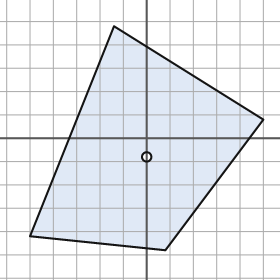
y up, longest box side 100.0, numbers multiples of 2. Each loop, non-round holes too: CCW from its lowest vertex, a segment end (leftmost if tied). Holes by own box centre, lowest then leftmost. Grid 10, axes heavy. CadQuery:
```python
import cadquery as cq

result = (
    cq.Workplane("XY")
    .moveTo(8.0, -48.0)
    .lineTo(50.0, 8.0)
    .lineTo(-14.0, 48.0)
    .lineTo(-50.0, -42.0)
    .close()
    .moveTo(0.0, -8.0)
    .circle(2.0)
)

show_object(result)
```